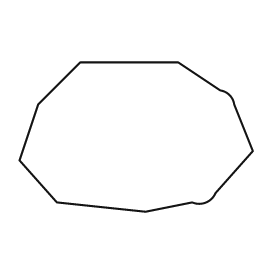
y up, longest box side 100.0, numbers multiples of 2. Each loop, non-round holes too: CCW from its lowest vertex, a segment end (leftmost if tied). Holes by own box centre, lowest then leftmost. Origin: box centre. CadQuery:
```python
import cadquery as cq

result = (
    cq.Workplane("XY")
    .moveTo(4.0, -32.0)
    .lineTo(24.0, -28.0)
    .threePointArc((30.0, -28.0), (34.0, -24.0))
    .lineTo(50.0, -6.0)
    .lineTo(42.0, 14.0)
    .threePointArc((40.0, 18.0), (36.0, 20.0))
    .lineTo(18.0, 32.0)
    .lineTo(-24.0, 32.0)
    .lineTo(-42.0, 14.0)
    .lineTo(-50.0, -10.0)
    .lineTo(-34.0, -28.0)
    .close()
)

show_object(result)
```